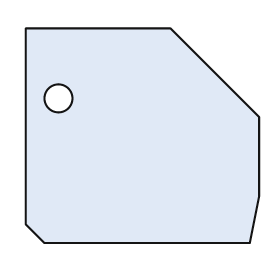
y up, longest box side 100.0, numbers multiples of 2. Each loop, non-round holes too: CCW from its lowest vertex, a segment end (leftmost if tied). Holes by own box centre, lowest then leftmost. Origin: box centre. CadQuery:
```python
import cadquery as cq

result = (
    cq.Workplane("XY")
    .moveTo(-42.0, -46.0)
    .lineTo(46.0, -46.0)
    .lineTo(50.0, -26.0)
    .lineTo(50.0, 8.0)
    .lineTo(12.0, 46.0)
    .lineTo(-50.0, 46.0)
    .lineTo(-50.0, -38.0)
    .close()
    .moveTo(-36.0, 16.0)
    .circle(6.0)
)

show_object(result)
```